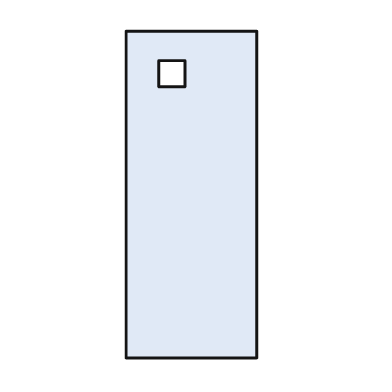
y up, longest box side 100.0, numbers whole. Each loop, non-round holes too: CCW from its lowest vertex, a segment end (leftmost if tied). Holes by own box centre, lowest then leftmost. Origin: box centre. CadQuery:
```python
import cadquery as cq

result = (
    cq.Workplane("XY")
    .moveTo(-20.0, -50.0)
    .lineTo(20.0, -50.0)
    .lineTo(20.0, 50.0)
    .lineTo(-20.0, 50.0)
    .close()
    .moveTo(-10.0, 33.0)
    .lineTo(-2.0, 33.0)
    .lineTo(-2.0, 41.0)
    .lineTo(-10.0, 41.0)
    .close()
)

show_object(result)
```